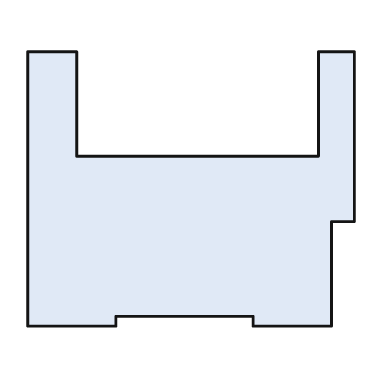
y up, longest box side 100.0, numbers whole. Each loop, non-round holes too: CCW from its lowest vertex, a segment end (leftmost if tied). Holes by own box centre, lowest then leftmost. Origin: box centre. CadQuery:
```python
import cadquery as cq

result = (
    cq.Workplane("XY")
    .moveTo(-50.0, -42.0)
    .lineTo(-23.0, -42.0)
    .lineTo(-23.0, -39.0)
    .lineTo(19.0, -39.0)
    .lineTo(19.0, -42.0)
    .lineTo(43.0, -42.0)
    .lineTo(43.0, -10.0)
    .lineTo(50.0, -10.0)
    .lineTo(50.0, 42.0)
    .lineTo(39.0, 42.0)
    .lineTo(39.0, 10.0)
    .lineTo(-35.0, 10.0)
    .lineTo(-35.0, 42.0)
    .lineTo(-50.0, 42.0)
    .close()
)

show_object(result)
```